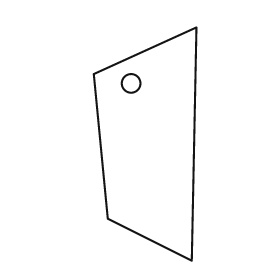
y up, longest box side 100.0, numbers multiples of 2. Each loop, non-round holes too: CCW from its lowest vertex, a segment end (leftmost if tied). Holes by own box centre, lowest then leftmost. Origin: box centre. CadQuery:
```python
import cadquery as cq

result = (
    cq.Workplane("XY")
    .moveTo(20.0, -50.0)
    .lineTo(22.0, 50.0)
    .lineTo(-22.0, 30.0)
    .lineTo(-16.0, -32.0)
    .close()
    .moveTo(-6.0, 26.0)
    .circle(4.0)
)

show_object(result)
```